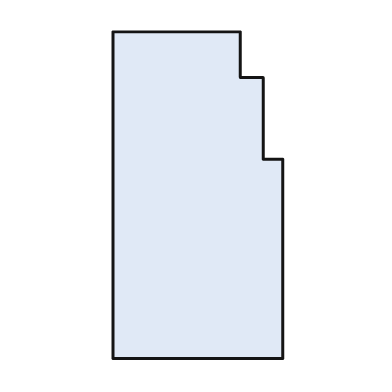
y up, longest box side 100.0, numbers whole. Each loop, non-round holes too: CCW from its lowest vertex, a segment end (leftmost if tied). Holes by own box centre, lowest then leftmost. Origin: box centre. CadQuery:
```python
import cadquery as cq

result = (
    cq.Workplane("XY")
    .moveTo(-26.0, -50.0)
    .lineTo(26.0, -50.0)
    .lineTo(26.0, 11.0)
    .lineTo(20.0, 11.0)
    .lineTo(20.0, 36.0)
    .lineTo(13.0, 36.0)
    .lineTo(13.0, 50.0)
    .lineTo(-26.0, 50.0)
    .close()
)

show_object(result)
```